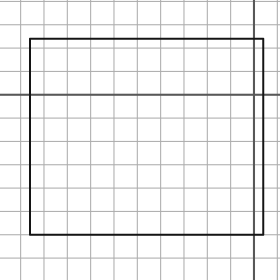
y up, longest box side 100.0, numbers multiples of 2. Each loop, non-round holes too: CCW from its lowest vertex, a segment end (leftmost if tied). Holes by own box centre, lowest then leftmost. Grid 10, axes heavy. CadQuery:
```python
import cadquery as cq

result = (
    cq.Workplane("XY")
    .moveTo(-96.0, -60.0)
    .lineTo(4.0, -60.0)
    .lineTo(4.0, 24.0)
    .lineTo(-96.0, 24.0)
    .close()
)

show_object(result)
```